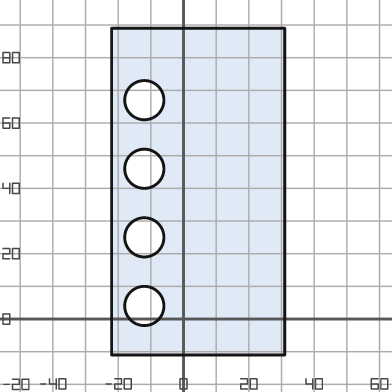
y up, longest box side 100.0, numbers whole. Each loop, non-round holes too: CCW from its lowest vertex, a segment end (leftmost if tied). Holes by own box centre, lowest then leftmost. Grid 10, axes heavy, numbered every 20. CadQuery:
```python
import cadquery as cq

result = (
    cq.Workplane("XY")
    .moveTo(-22.0, -11.0)
    .lineTo(31.0, -11.0)
    .lineTo(31.0, 89.0)
    .lineTo(-22.0, 89.0)
    .close()
    .moveTo(-12.0, 4.0)
    .circle(6.0)
    .moveTo(-12.0, 25.0)
    .circle(6.0)
    .moveTo(-12.0, 46.0)
    .circle(6.0)
    .moveTo(-12.0, 67.0)
    .circle(6.0)
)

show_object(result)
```